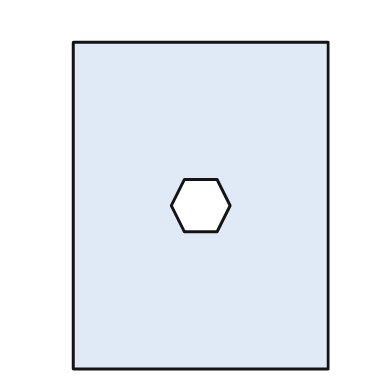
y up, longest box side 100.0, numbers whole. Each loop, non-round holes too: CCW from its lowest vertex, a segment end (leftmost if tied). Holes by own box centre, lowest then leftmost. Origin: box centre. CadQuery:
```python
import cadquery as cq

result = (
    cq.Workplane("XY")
    .moveTo(-39.0, -50.0)
    .lineTo(39.0, -50.0)
    .lineTo(39.0, 50.0)
    .lineTo(-39.0, 50.0)
    .close()
    .moveTo(-5.0, -8.0)
    .lineTo(5.0, -8.0)
    .lineTo(9.0, 0.0)
    .lineTo(5.0, 8.0)
    .lineTo(-5.0, 8.0)
    .lineTo(-9.0, 0.0)
    .close()
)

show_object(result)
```